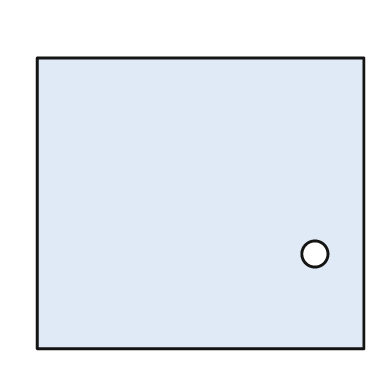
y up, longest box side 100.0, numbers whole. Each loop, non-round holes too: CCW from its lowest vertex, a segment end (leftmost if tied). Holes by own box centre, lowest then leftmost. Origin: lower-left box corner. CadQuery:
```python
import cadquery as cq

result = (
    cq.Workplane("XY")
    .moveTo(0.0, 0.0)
    .lineTo(100.0, 0.0)
    .lineTo(100.0, 89.0)
    .lineTo(0.0, 89.0)
    .close()
    .moveTo(85.0, 29.0)
    .circle(4.0)
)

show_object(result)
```